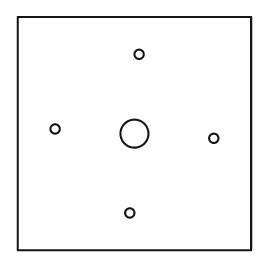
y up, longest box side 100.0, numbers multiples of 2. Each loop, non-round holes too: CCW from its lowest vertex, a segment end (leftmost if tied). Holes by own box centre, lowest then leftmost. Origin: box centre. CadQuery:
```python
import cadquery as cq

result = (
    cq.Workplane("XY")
    .moveTo(-50.0, -50.0)
    .lineTo(50.0, -50.0)
    .lineTo(50.0, 50.0)
    .lineTo(-50.0, 50.0)
    .close()
    .moveTo(-2.0, -34.0)
    .circle(2.0)
    .moveTo(34.0, -2.0)
    .circle(2.0)
    .moveTo(0.0, 0.0)
    .circle(6.0)
    .moveTo(-34.0, 2.0)
    .circle(2.0)
    .moveTo(2.0, 34.0)
    .circle(2.0)
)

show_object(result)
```